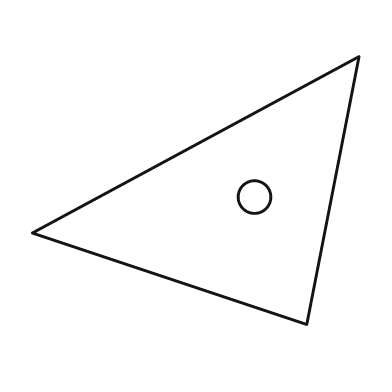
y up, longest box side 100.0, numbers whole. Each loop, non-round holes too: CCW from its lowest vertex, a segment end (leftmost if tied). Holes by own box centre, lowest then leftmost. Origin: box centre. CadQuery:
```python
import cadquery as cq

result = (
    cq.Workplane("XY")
    .moveTo(34.0, -41.0)
    .lineTo(50.0, 41.0)
    .lineTo(-50.0, -13.0)
    .close()
    .moveTo(18.0, -2.0)
    .circle(5.0)
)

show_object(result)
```